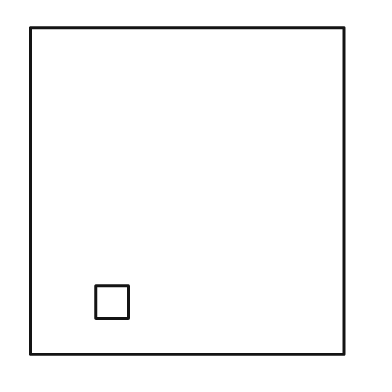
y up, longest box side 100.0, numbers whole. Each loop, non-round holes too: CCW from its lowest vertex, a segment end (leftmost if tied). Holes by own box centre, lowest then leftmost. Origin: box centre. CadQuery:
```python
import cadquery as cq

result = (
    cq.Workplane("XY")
    .moveTo(-48.0, -50.0)
    .lineTo(48.0, -50.0)
    .lineTo(48.0, 50.0)
    .lineTo(-48.0, 50.0)
    .close()
    .moveTo(-28.0, -39.0)
    .lineTo(-18.0, -39.0)
    .lineTo(-18.0, -29.0)
    .lineTo(-28.0, -29.0)
    .close()
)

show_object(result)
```